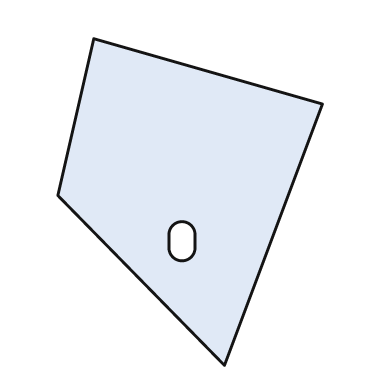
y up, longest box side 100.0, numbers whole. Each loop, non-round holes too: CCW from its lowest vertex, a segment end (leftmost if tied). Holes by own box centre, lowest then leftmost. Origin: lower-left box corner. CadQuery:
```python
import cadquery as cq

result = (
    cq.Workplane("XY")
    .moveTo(51.0, 0.0)
    .lineTo(81.0, 80.0)
    .lineTo(11.0, 100.0)
    .lineTo(0.0, 52.0)
    .close()
    .moveTo(34.0, 36.0)
    .threePointArc((38.0, 32.0), (42.0, 36.0))
    .lineTo(42.0, 40.0)
    .threePointArc((38.0, 44.0), (34.0, 40.0))
    .close()
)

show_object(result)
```